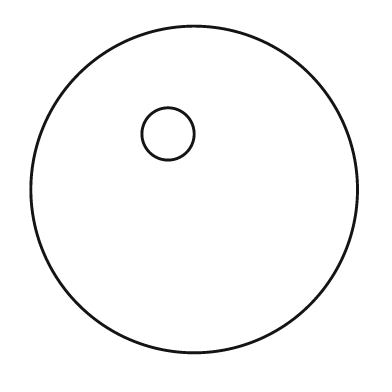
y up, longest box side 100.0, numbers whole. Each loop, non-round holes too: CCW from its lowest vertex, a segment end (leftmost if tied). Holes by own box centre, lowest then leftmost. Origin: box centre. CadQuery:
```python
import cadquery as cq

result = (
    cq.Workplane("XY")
    .moveTo(0.0, 0.0)
    .circle(50.0)
    .moveTo(-8.0, 17.0)
    .circle(8.0)
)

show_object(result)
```